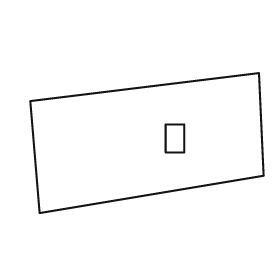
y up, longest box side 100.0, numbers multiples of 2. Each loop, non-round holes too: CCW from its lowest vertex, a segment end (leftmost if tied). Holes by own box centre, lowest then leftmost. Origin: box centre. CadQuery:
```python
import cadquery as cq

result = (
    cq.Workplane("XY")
    .moveTo(-46.0, -30.0)
    .lineTo(50.0, -14.0)
    .lineTo(48.0, 30.0)
    .lineTo(-50.0, 18.0)
    .close()
    .moveTo(8.0, -4.0)
    .lineTo(16.0, -4.0)
    .lineTo(16.0, 8.0)
    .lineTo(8.0, 8.0)
    .close()
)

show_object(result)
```